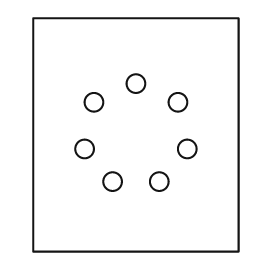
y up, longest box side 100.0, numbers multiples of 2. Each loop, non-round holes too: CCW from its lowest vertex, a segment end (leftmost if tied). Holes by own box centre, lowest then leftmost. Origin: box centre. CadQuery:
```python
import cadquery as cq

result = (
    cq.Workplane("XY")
    .moveTo(-44.0, -50.0)
    .lineTo(44.0, -50.0)
    .lineTo(44.0, 50.0)
    .lineTo(-44.0, 50.0)
    .close()
    .moveTo(-10.0, -20.0)
    .circle(4.0)
    .moveTo(10.0, -20.0)
    .circle(4.0)
    .moveTo(-22.0, -6.0)
    .circle(4.0)
    .moveTo(22.0, -6.0)
    .circle(4.0)
    .moveTo(-18.0, 14.0)
    .circle(4.0)
    .moveTo(18.0, 14.0)
    .circle(4.0)
    .moveTo(0.0, 22.0)
    .circle(4.0)
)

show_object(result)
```